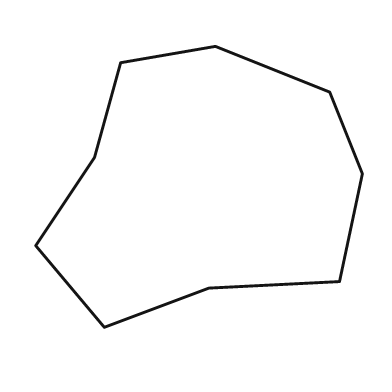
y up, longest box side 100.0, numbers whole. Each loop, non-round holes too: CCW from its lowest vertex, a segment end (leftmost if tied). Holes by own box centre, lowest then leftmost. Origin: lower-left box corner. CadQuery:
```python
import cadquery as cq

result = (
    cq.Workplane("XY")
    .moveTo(21.0, 0.0)
    .lineTo(53.0, 12.0)
    .lineTo(93.0, 14.0)
    .lineTo(100.0, 47.0)
    .lineTo(90.0, 72.0)
    .lineTo(55.0, 86.0)
    .lineTo(26.0, 81.0)
    .lineTo(18.0, 52.0)
    .lineTo(0.0, 25.0)
    .close()
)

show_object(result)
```